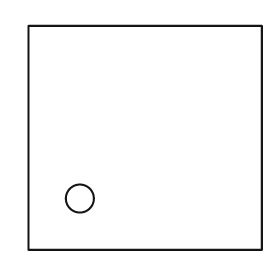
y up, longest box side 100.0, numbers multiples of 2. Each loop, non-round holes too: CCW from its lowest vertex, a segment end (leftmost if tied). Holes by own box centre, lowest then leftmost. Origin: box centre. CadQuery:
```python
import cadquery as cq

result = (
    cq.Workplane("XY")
    .moveTo(-50.0, -48.0)
    .lineTo(50.0, -48.0)
    .lineTo(50.0, 48.0)
    .lineTo(-50.0, 48.0)
    .close()
    .moveTo(-28.0, -26.0)
    .circle(6.0)
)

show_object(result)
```